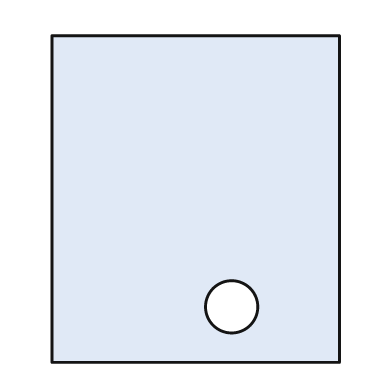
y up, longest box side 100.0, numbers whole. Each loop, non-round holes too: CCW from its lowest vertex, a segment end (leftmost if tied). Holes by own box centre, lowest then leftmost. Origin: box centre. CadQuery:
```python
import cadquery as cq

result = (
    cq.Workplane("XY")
    .moveTo(-44.0, -50.0)
    .lineTo(44.0, -50.0)
    .lineTo(44.0, 50.0)
    .lineTo(-44.0, 50.0)
    .close()
    .moveTo(11.0, -33.0)
    .circle(8.0)
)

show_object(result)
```